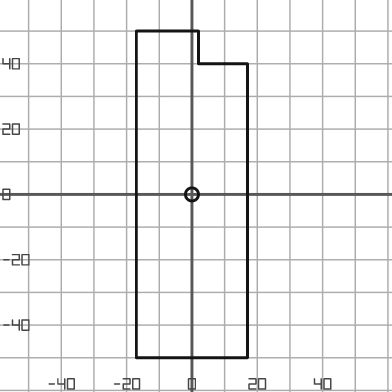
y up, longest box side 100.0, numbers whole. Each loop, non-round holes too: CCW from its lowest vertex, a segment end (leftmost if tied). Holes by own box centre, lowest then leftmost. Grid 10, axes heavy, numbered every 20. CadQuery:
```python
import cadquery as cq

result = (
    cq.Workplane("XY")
    .moveTo(-17.0, -50.0)
    .lineTo(17.0, -50.0)
    .lineTo(17.0, 40.0)
    .lineTo(2.0, 40.0)
    .lineTo(2.0, 50.0)
    .lineTo(-17.0, 50.0)
    .close()
    .moveTo(0.0, 0.0)
    .circle(2.0)
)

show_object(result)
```